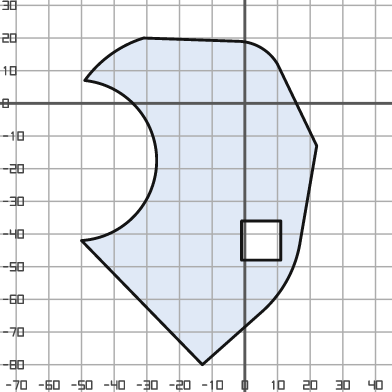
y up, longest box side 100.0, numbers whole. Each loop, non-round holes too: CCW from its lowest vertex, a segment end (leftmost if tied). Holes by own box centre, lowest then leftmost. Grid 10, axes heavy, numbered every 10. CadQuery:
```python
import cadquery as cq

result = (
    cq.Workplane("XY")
    .moveTo(-13.0, -80.0)
    .lineTo(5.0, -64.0)
    .threePointArc((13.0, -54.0), (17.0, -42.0))
    .lineTo(22.0, -13.0)
    .lineTo(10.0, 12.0)
    .threePointArc((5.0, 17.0), (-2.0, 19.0))
    .lineTo(-31.0, 20.0)
    .threePointArc((-41.0, 15.0), (-49.0, 7.0))
    .threePointArc((-27.0, -18.0), (-50.0, -42.0))
    .close()
    .moveTo(-1.0, -48.0)
    .lineTo(11.0, -48.0)
    .lineTo(11.0, -36.0)
    .lineTo(-1.0, -36.0)
    .close()
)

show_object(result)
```